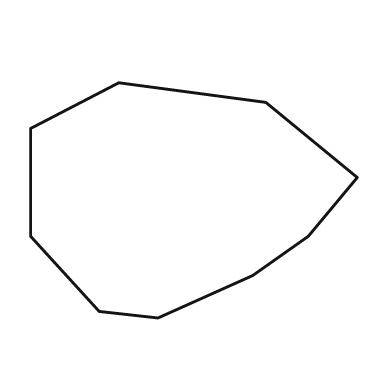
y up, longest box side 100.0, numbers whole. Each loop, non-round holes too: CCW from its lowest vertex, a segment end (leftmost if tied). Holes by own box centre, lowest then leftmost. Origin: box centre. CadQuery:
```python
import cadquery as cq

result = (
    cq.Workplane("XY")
    .moveTo(-11.0, -36.0)
    .lineTo(18.0, -23.0)
    .lineTo(35.0, -11.0)
    .lineTo(50.0, 7.0)
    .lineTo(22.0, 30.0)
    .lineTo(-23.0, 36.0)
    .lineTo(-50.0, 22.0)
    .lineTo(-50.0, -11.0)
    .lineTo(-29.0, -34.0)
    .close()
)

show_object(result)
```